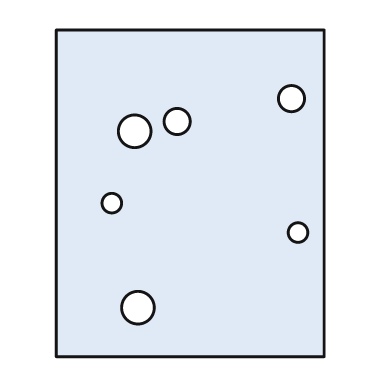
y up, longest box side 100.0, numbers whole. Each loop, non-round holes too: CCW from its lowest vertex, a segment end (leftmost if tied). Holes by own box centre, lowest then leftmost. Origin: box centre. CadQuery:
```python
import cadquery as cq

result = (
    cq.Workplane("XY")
    .moveTo(-41.0, -50.0)
    .lineTo(41.0, -50.0)
    .lineTo(41.0, 50.0)
    .lineTo(-41.0, 50.0)
    .close()
    .moveTo(-16.0, -35.0)
    .circle(5.0)
    .moveTo(33.0, -12.0)
    .circle(3.0)
    .moveTo(-24.0, -3.0)
    .circle(3.0)
    .moveTo(-17.0, 19.0)
    .circle(5.0)
    .moveTo(-4.0, 22.0)
    .circle(4.0)
    .moveTo(31.0, 29.0)
    .circle(4.0)
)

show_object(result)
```